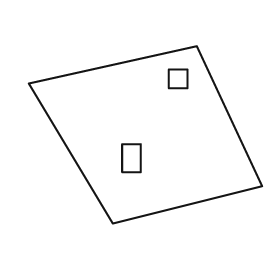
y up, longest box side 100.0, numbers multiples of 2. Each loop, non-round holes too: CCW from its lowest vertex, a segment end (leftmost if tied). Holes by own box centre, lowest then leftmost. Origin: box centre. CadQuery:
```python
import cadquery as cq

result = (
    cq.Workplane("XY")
    .moveTo(-14.0, -38.0)
    .lineTo(50.0, -22.0)
    .lineTo(22.0, 38.0)
    .lineTo(-50.0, 22.0)
    .close()
    .moveTo(-10.0, -16.0)
    .lineTo(-2.0, -16.0)
    .lineTo(-2.0, -4.0)
    .lineTo(-10.0, -4.0)
    .close()
    .moveTo(10.0, 20.0)
    .lineTo(18.0, 20.0)
    .lineTo(18.0, 28.0)
    .lineTo(10.0, 28.0)
    .close()
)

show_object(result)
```